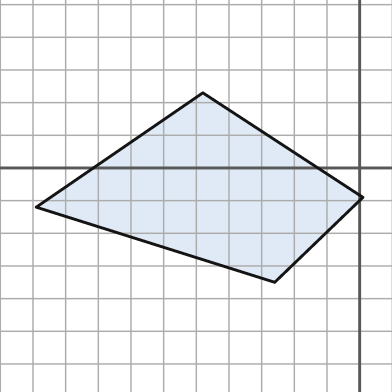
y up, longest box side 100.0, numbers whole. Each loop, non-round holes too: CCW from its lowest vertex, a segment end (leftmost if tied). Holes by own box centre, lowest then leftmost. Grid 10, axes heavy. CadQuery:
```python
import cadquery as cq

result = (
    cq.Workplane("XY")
    .moveTo(-26.0, -35.0)
    .lineTo(1.0, -9.0)
    .lineTo(-48.0, 23.0)
    .lineTo(-99.0, -12.0)
    .close()
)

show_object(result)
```